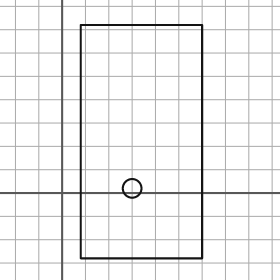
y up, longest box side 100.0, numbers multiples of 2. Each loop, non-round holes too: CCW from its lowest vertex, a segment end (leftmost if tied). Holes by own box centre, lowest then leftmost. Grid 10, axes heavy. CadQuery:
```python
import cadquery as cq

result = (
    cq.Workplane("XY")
    .moveTo(8.0, -28.0)
    .lineTo(60.0, -28.0)
    .lineTo(60.0, 72.0)
    .lineTo(8.0, 72.0)
    .close()
    .moveTo(30.0, 2.0)
    .circle(4.0)
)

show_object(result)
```